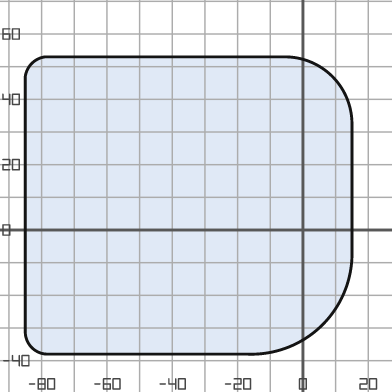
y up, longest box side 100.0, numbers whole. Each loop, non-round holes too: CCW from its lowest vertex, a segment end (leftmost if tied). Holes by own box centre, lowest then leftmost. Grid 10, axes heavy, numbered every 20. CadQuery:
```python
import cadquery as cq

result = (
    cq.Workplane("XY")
    .moveTo(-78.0, -38.0)
    .lineTo(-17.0, -38.0)
    .threePointArc((6.0, -29.0), (15.0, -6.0))
    .lineTo(15.0, 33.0)
    .threePointArc((9.0, 47.0), (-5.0, 53.0))
    .lineTo(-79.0, 53.0)
    .threePointArc((-83.0, 51.0), (-85.0, 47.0))
    .lineTo(-85.0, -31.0)
    .threePointArc((-83.0, -36.0), (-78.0, -38.0))
    .close()
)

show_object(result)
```